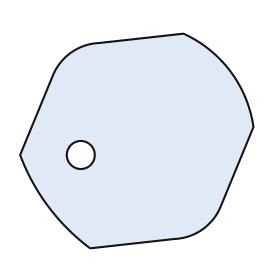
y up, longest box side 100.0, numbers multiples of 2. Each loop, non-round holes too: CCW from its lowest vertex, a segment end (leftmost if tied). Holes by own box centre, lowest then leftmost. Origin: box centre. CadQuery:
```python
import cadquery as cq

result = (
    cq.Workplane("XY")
    .moveTo(-20.0, -46.0)
    .lineTo(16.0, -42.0)
    .threePointArc((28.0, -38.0), (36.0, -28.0))
    .lineTo(50.0, 6.0)
    .threePointArc((40.0, 30.0), (20.0, 46.0))
    .lineTo(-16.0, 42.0)
    .threePointArc((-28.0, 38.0), (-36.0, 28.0))
    .lineTo(-50.0, -6.0)
    .threePointArc((-38.0, -28.0), (-20.0, -46.0))
    .close()
    .moveTo(-24.0, -6.0)
    .circle(6.0)
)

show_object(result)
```